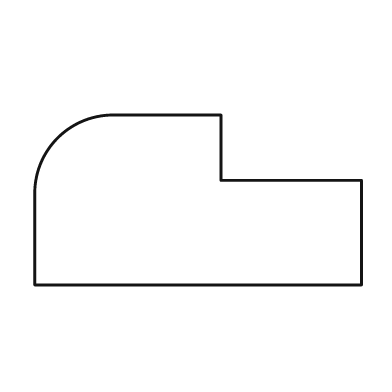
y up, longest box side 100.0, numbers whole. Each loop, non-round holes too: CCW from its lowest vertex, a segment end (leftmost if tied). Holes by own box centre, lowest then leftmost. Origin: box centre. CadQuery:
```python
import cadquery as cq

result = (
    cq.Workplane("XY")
    .moveTo(-50.0, -26.0)
    .lineTo(50.0, -26.0)
    .lineTo(50.0, 6.0)
    .lineTo(7.0, 6.0)
    .lineTo(7.0, 26.0)
    .lineTo(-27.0, 26.0)
    .threePointArc((-43.0, 19.0), (-50.0, 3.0))
    .close()
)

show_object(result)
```